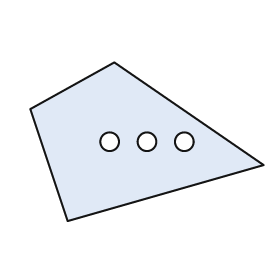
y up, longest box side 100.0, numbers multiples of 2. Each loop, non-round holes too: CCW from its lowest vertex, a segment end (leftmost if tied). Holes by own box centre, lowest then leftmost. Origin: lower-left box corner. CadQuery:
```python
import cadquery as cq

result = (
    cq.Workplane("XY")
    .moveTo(16.0, 0.0)
    .lineTo(100.0, 24.0)
    .lineTo(36.0, 68.0)
    .lineTo(0.0, 48.0)
    .close()
    .moveTo(34.0, 34.0)
    .circle(4.0)
    .moveTo(50.0, 34.0)
    .circle(4.0)
    .moveTo(66.0, 34.0)
    .circle(4.0)
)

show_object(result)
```